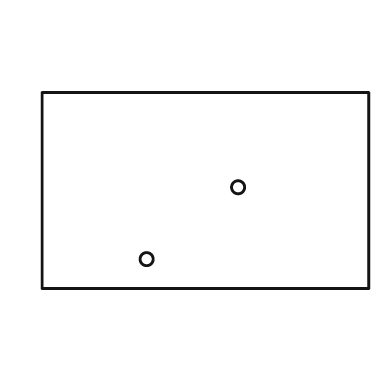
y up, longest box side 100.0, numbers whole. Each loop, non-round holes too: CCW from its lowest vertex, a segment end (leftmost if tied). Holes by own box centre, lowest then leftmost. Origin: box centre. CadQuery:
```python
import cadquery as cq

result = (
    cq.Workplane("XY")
    .moveTo(-50.0, -30.0)
    .lineTo(50.0, -30.0)
    .lineTo(50.0, 30.0)
    .lineTo(-50.0, 30.0)
    .close()
    .moveTo(-18.0, -21.0)
    .circle(2.0)
    .moveTo(10.0, 1.0)
    .circle(2.0)
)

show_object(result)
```